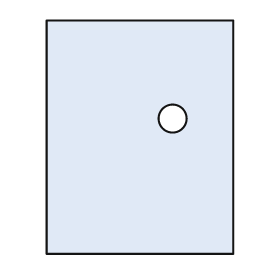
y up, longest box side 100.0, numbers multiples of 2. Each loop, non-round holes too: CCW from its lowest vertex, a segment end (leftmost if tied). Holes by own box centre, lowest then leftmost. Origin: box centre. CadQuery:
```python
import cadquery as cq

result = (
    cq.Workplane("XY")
    .moveTo(-40.0, -50.0)
    .lineTo(40.0, -50.0)
    .lineTo(40.0, 50.0)
    .lineTo(-40.0, 50.0)
    .close()
    .moveTo(14.0, 8.0)
    .circle(6.0)
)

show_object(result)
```